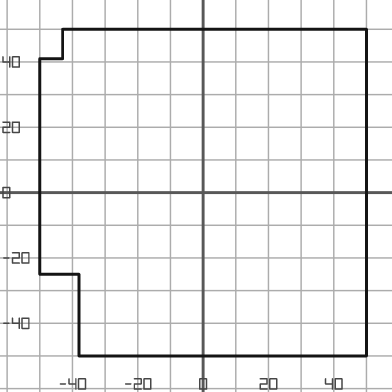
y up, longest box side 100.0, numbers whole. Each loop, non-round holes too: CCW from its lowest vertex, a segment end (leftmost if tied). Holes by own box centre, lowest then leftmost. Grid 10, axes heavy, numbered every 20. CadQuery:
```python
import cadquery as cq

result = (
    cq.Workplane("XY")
    .moveTo(-38.0, -50.0)
    .lineTo(50.0, -50.0)
    .lineTo(50.0, 50.0)
    .lineTo(-43.0, 50.0)
    .lineTo(-43.0, 41.0)
    .lineTo(-50.0, 41.0)
    .lineTo(-50.0, -25.0)
    .lineTo(-38.0, -25.0)
    .close()
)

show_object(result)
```